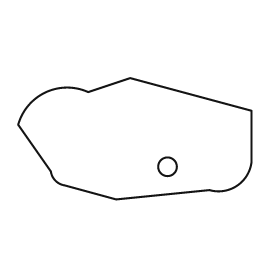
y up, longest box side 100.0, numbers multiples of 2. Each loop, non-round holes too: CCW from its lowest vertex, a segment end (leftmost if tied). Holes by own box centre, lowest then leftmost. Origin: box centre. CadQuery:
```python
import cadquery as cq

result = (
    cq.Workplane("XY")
    .moveTo(-8.0, -26.0)
    .lineTo(32.0, -22.0)
    .threePointArc((44.0, -20.0), (50.0, -10.0))
    .lineTo(50.0, 12.0)
    .lineTo(-2.0, 26.0)
    .lineTo(-20.0, 20.0)
    .threePointArc((-38.0, 20.0), (-50.0, 6.0))
    .lineTo(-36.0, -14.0)
    .threePointArc((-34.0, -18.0), (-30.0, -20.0))
    .close()
    .moveTo(14.0, -12.0)
    .circle(4.0)
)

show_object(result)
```